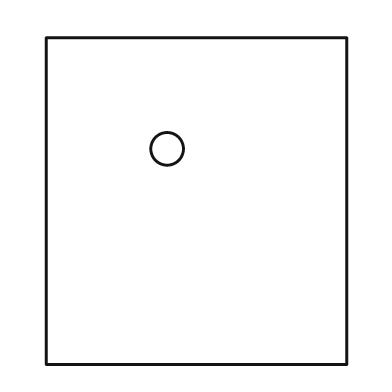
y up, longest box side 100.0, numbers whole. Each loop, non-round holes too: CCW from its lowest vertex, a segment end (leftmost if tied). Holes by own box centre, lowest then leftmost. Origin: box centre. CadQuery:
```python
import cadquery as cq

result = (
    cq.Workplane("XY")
    .moveTo(-46.0, -50.0)
    .lineTo(46.0, -50.0)
    .lineTo(46.0, 50.0)
    .lineTo(-46.0, 50.0)
    .close()
    .moveTo(-9.0, 16.0)
    .circle(5.0)
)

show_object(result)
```